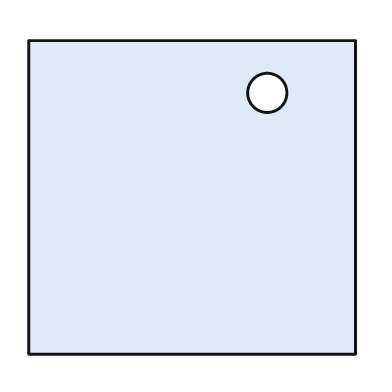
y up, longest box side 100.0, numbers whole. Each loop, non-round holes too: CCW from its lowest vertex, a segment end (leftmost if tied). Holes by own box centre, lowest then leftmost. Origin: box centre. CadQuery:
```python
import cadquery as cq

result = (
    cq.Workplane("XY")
    .moveTo(-50.0, -48.0)
    .lineTo(50.0, -48.0)
    .lineTo(50.0, 48.0)
    .lineTo(-50.0, 48.0)
    .close()
    .moveTo(23.0, 32.0)
    .circle(6.0)
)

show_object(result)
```